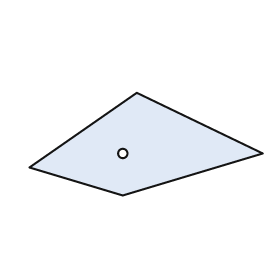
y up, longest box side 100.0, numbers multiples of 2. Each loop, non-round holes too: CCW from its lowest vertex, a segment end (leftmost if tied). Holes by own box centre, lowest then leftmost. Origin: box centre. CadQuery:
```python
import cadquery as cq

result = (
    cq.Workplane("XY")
    .moveTo(-10.0, -22.0)
    .lineTo(50.0, -4.0)
    .lineTo(-4.0, 22.0)
    .lineTo(-50.0, -10.0)
    .close()
    .moveTo(-10.0, -4.0)
    .circle(2.0)
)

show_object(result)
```